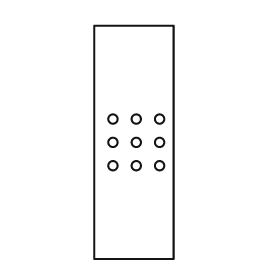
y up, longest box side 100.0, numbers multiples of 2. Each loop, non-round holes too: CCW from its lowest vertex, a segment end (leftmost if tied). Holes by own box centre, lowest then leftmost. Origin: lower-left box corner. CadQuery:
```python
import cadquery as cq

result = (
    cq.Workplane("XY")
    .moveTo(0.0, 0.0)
    .lineTo(34.0, 0.0)
    .lineTo(34.0, 100.0)
    .lineTo(0.0, 100.0)
    .close()
    .moveTo(8.0, 40.0)
    .circle(2.0)
    .moveTo(18.0, 40.0)
    .circle(2.0)
    .moveTo(28.0, 40.0)
    .circle(2.0)
    .moveTo(8.0, 50.0)
    .circle(2.0)
    .moveTo(18.0, 50.0)
    .circle(2.0)
    .moveTo(28.0, 50.0)
    .circle(2.0)
    .moveTo(8.0, 60.0)
    .circle(2.0)
    .moveTo(18.0, 60.0)
    .circle(2.0)
    .moveTo(28.0, 60.0)
    .circle(2.0)
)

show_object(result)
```